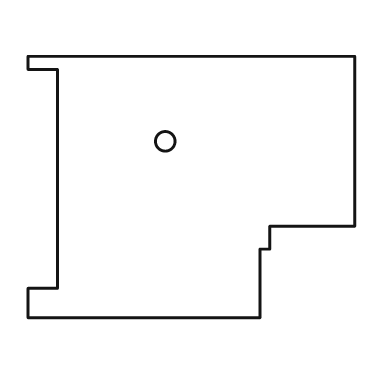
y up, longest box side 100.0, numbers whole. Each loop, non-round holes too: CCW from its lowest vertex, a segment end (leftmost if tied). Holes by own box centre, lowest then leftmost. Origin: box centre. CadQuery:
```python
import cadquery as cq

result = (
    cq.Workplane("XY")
    .moveTo(-50.0, -40.0)
    .lineTo(21.0, -40.0)
    .lineTo(21.0, -19.0)
    .lineTo(24.0, -19.0)
    .lineTo(24.0, -12.0)
    .lineTo(50.0, -12.0)
    .lineTo(50.0, 40.0)
    .lineTo(-50.0, 40.0)
    .lineTo(-50.0, 36.0)
    .lineTo(-41.0, 36.0)
    .lineTo(-41.0, -31.0)
    .lineTo(-50.0, -31.0)
    .close()
    .moveTo(-8.0, 14.0)
    .circle(3.0)
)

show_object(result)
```